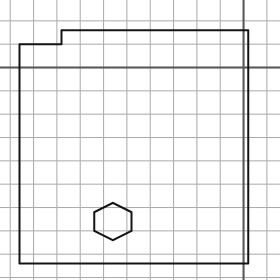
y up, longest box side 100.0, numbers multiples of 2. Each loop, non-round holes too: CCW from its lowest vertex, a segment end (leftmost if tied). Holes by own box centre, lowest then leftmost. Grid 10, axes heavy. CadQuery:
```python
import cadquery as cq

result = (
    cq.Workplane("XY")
    .moveTo(-96.0, -84.0)
    .lineTo(2.0, -84.0)
    .lineTo(2.0, 16.0)
    .lineTo(-78.0, 16.0)
    .lineTo(-78.0, 10.0)
    .lineTo(-96.0, 10.0)
    .close()
    .moveTo(-56.0, -74.0)
    .lineTo(-48.0, -70.0)
    .lineTo(-48.0, -62.0)
    .lineTo(-56.0, -58.0)
    .lineTo(-64.0, -62.0)
    .lineTo(-64.0, -70.0)
    .close()
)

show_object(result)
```